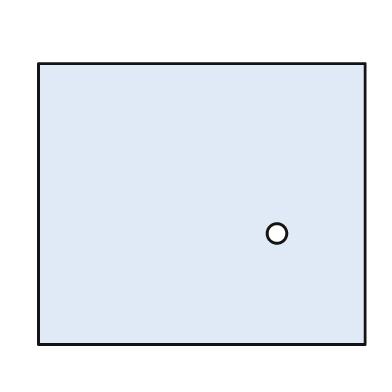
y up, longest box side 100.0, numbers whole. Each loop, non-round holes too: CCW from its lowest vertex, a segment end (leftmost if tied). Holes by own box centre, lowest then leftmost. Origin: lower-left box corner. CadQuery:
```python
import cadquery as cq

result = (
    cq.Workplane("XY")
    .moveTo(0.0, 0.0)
    .lineTo(100.0, 0.0)
    .lineTo(100.0, 86.0)
    .lineTo(0.0, 86.0)
    .close()
    .moveTo(73.0, 34.0)
    .circle(3.0)
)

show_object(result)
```